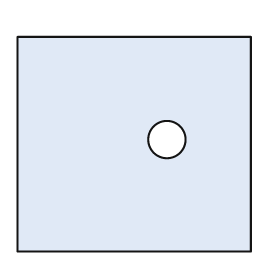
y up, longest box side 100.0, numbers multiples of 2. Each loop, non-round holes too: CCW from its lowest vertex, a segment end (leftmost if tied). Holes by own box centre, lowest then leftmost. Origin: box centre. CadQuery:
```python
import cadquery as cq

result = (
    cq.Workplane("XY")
    .moveTo(-50.0, -46.0)
    .lineTo(50.0, -46.0)
    .lineTo(50.0, 46.0)
    .lineTo(-50.0, 46.0)
    .close()
    .moveTo(14.0, 2.0)
    .circle(8.0)
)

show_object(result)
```